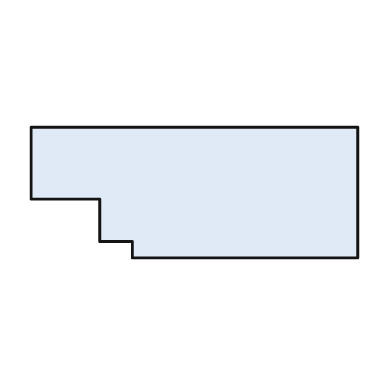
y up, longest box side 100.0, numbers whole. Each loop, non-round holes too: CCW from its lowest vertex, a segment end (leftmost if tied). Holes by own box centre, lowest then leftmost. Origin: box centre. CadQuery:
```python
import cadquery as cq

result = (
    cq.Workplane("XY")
    .moveTo(-19.0, -20.0)
    .lineTo(50.0, -20.0)
    .lineTo(50.0, 20.0)
    .lineTo(-50.0, 20.0)
    .lineTo(-50.0, -2.0)
    .lineTo(-29.0, -2.0)
    .lineTo(-29.0, -15.0)
    .lineTo(-19.0, -15.0)
    .close()
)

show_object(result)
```